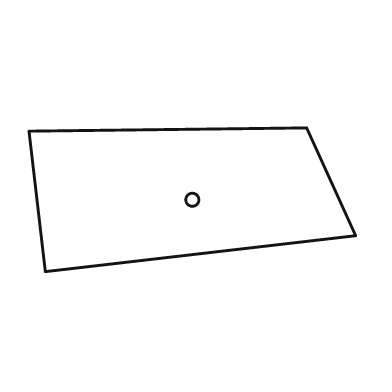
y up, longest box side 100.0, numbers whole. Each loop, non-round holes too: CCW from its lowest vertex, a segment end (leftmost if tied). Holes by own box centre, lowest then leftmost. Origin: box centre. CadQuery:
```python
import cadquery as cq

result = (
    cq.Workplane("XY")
    .moveTo(-45.0, -22.0)
    .lineTo(50.0, -11.0)
    .lineTo(35.0, 22.0)
    .lineTo(-50.0, 21.0)
    .close()
    .moveTo(0.0, 0.0)
    .circle(2.0)
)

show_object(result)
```